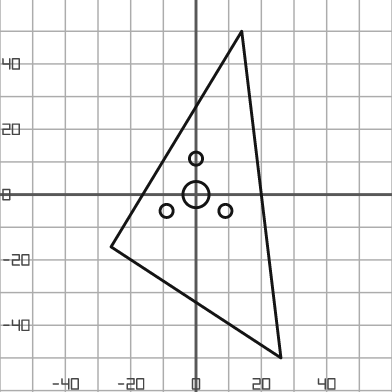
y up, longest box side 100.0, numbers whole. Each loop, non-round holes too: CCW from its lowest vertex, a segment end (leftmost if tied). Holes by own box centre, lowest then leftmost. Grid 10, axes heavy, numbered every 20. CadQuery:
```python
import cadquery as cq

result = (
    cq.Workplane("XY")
    .moveTo(26.0, -50.0)
    .lineTo(14.0, 50.0)
    .lineTo(-26.0, -16.0)
    .close()
    .moveTo(-9.0, -5.0)
    .circle(2.0)
    .moveTo(9.0, -5.0)
    .circle(2.0)
    .moveTo(0.0, 0.0)
    .circle(4.0)
    .moveTo(0.0, 11.0)
    .circle(2.0)
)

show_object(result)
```